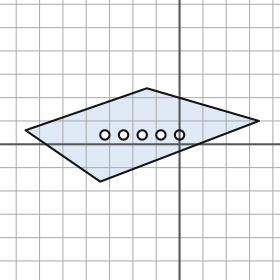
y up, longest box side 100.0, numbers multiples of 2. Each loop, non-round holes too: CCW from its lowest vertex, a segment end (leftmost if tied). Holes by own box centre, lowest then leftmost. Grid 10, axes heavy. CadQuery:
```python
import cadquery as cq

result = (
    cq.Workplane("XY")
    .moveTo(-34.0, -16.0)
    .lineTo(34.0, 10.0)
    .lineTo(-14.0, 24.0)
    .lineTo(-66.0, 6.0)
    .close()
    .moveTo(-32.0, 4.0)
    .circle(2.0)
    .moveTo(-24.0, 4.0)
    .circle(2.0)
    .moveTo(-16.0, 4.0)
    .circle(2.0)
    .moveTo(-8.0, 4.0)
    .circle(2.0)
    .moveTo(0.0, 4.0)
    .circle(2.0)
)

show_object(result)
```